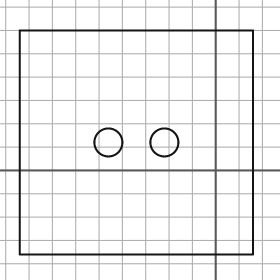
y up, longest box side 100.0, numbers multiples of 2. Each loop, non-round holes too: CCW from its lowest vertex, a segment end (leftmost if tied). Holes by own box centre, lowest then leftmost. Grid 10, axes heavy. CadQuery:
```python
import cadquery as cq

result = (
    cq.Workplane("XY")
    .moveTo(-84.0, -36.0)
    .lineTo(16.0, -36.0)
    .lineTo(16.0, 60.0)
    .lineTo(-84.0, 60.0)
    .close()
    .moveTo(-46.0, 12.0)
    .circle(6.0)
    .moveTo(-22.0, 12.0)
    .circle(6.0)
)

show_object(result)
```